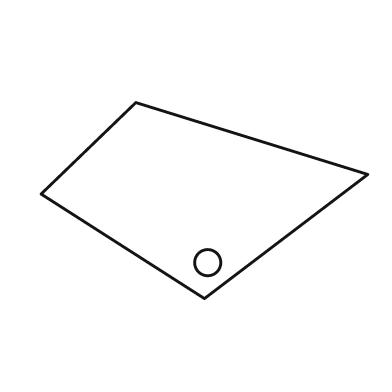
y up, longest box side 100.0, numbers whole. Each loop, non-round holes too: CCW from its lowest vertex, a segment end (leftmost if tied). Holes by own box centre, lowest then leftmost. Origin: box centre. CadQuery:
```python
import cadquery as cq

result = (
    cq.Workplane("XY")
    .moveTo(0.0, -30.0)
    .lineTo(50.0, 8.0)
    .lineTo(-21.0, 30.0)
    .lineTo(-50.0, 2.0)
    .close()
    .moveTo(1.0, -19.0)
    .circle(4.0)
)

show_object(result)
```